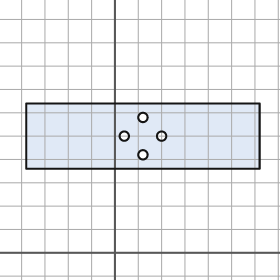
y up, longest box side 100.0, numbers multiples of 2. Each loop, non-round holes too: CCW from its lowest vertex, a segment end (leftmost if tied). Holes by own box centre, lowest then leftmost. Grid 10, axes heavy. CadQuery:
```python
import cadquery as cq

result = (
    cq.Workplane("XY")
    .moveTo(-38.0, 36.0)
    .lineTo(62.0, 36.0)
    .lineTo(62.0, 64.0)
    .lineTo(-38.0, 64.0)
    .close()
    .moveTo(12.0, 42.0)
    .circle(2.0)
    .moveTo(4.0, 50.0)
    .circle(2.0)
    .moveTo(20.0, 50.0)
    .circle(2.0)
    .moveTo(12.0, 58.0)
    .circle(2.0)
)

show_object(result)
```